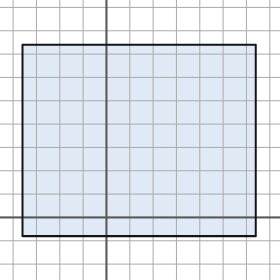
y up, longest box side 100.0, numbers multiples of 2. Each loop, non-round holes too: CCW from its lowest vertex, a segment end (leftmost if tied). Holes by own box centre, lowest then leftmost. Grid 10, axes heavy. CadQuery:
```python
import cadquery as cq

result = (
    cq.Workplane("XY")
    .moveTo(-36.0, -8.0)
    .lineTo(64.0, -8.0)
    .lineTo(64.0, 74.0)
    .lineTo(-36.0, 74.0)
    .close()
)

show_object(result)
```